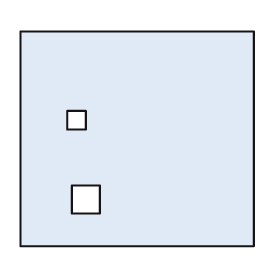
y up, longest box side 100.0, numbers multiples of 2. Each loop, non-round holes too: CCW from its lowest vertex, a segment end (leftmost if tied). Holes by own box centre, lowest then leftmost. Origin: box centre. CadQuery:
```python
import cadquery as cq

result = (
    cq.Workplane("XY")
    .moveTo(-50.0, -46.0)
    .lineTo(50.0, -46.0)
    .lineTo(50.0, 46.0)
    .lineTo(-50.0, 46.0)
    .close()
    .moveTo(-28.0, -32.0)
    .lineTo(-16.0, -32.0)
    .lineTo(-16.0, -20.0)
    .lineTo(-28.0, -20.0)
    .close()
    .moveTo(-30.0, 4.0)
    .lineTo(-22.0, 4.0)
    .lineTo(-22.0, 12.0)
    .lineTo(-30.0, 12.0)
    .close()
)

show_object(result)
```